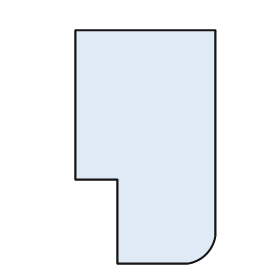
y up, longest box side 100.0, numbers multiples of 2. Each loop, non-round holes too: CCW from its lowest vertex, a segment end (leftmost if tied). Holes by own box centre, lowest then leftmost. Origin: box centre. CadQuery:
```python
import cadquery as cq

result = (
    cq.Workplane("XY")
    .moveTo(-12.0, -50.0)
    .lineTo(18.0, -50.0)
    .threePointArc((26.0, -46.0), (30.0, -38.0))
    .lineTo(30.0, 50.0)
    .lineTo(-30.0, 50.0)
    .lineTo(-30.0, -14.0)
    .lineTo(-12.0, -14.0)
    .close()
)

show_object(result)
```